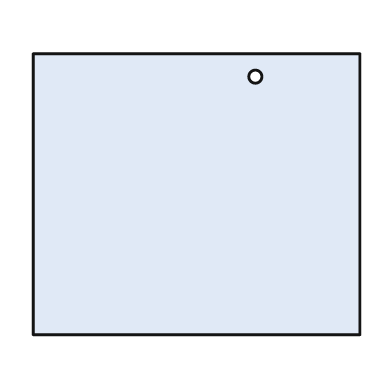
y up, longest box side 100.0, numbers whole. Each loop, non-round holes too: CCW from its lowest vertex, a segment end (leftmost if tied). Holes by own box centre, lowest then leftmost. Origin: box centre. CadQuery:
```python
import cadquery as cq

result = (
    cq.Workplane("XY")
    .moveTo(-50.0, -43.0)
    .lineTo(50.0, -43.0)
    .lineTo(50.0, 43.0)
    .lineTo(-50.0, 43.0)
    .close()
    .moveTo(18.0, 36.0)
    .circle(2.0)
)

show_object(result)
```